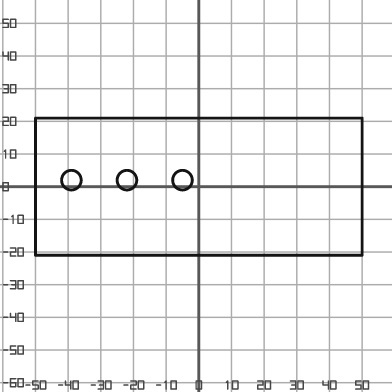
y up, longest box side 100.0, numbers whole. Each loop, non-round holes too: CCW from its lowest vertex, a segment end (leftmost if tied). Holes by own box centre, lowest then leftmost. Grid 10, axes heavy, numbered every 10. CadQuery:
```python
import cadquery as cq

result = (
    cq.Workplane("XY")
    .moveTo(-50.0, -21.0)
    .lineTo(50.0, -21.0)
    .lineTo(50.0, 21.0)
    .lineTo(-50.0, 21.0)
    .close()
    .moveTo(-39.0, 2.0)
    .circle(3.0)
    .moveTo(-22.0, 2.0)
    .circle(3.0)
    .moveTo(-5.0, 2.0)
    .circle(3.0)
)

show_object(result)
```